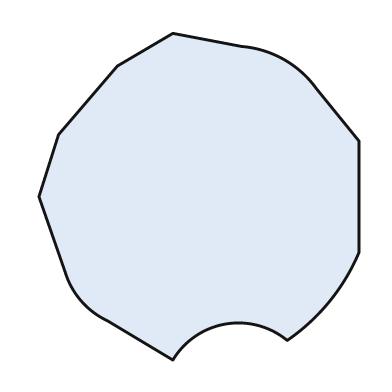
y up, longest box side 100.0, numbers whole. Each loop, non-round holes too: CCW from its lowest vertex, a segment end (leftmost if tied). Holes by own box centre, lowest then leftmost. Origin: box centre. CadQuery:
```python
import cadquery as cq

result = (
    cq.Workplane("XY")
    .moveTo(-8.0, -50.0)
    .threePointArc((8.0, -39.0), (27.0, -44.0))
    .threePointArc((40.0, -32.0), (49.0, -17.0))
    .lineTo(49.0, 17.0)
    .lineTo(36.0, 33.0)
    .threePointArc((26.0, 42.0), (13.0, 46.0))
    .lineTo(-8.0, 50.0)
    .lineTo(-25.0, 40.0)
    .lineTo(-43.0, 19.0)
    .lineTo(-49.0, 0.0)
    .lineTo(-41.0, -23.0)
    .threePointArc((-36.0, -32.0), (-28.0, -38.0))
    .close()
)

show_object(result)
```